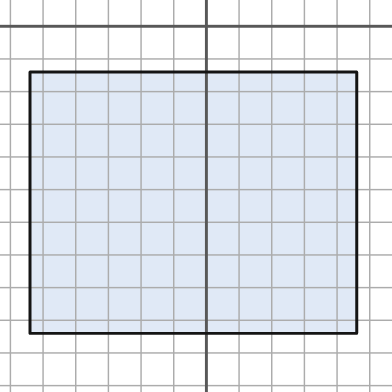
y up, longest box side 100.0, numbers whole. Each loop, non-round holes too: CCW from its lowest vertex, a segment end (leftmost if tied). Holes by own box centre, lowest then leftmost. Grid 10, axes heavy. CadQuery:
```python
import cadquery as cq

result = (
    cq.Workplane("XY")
    .moveTo(-54.0, -94.0)
    .lineTo(46.0, -94.0)
    .lineTo(46.0, -14.0)
    .lineTo(-54.0, -14.0)
    .close()
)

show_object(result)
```